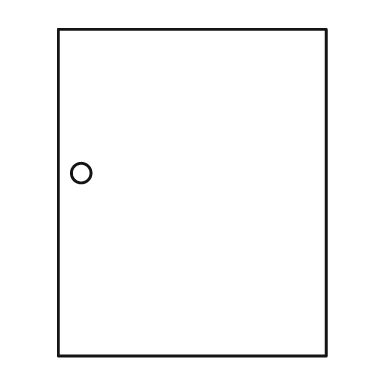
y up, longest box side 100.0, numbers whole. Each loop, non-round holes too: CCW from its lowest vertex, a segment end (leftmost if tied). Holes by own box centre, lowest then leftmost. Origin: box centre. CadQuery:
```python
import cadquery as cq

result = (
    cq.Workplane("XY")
    .moveTo(-41.0, -50.0)
    .lineTo(41.0, -50.0)
    .lineTo(41.0, 50.0)
    .lineTo(-41.0, 50.0)
    .close()
    .moveTo(-34.0, 6.0)
    .circle(3.0)
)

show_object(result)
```